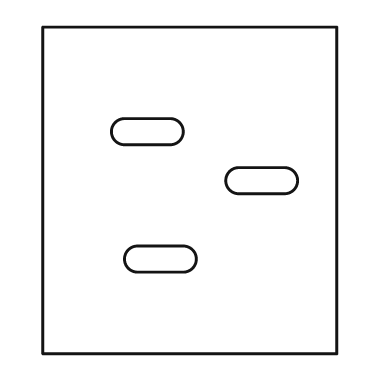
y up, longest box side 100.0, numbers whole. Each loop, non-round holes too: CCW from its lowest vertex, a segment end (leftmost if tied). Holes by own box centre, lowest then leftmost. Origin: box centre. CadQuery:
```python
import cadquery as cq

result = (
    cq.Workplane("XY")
    .moveTo(-45.0, -50.0)
    .lineTo(45.0, -50.0)
    .lineTo(45.0, 50.0)
    .lineTo(-45.0, 50.0)
    .close()
    .moveTo(-16.0, -25.0)
    .lineTo(-2.0, -25.0)
    .threePointArc((2.0, -21.0), (-2.0, -17.0))
    .lineTo(-16.0, -17.0)
    .threePointArc((-20.0, -21.0), (-16.0, -25.0))
    .close()
    .moveTo(15.0, -1.0)
    .lineTo(29.0, -1.0)
    .threePointArc((33.0, 3.0), (29.0, 7.0))
    .lineTo(15.0, 7.0)
    .threePointArc((11.0, 3.0), (15.0, -1.0))
    .close()
    .moveTo(-20.0, 14.0)
    .lineTo(-6.0, 14.0)
    .threePointArc((-2.0, 18.0), (-6.0, 22.0))
    .lineTo(-20.0, 22.0)
    .threePointArc((-24.0, 18.0), (-20.0, 14.0))
    .close()
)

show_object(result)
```